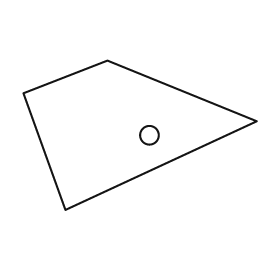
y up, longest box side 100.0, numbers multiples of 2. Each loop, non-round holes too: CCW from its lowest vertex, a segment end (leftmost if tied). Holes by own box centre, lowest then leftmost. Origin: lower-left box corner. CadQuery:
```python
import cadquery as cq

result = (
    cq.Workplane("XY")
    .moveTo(18.0, 0.0)
    .lineTo(100.0, 38.0)
    .lineTo(36.0, 64.0)
    .lineTo(0.0, 50.0)
    .close()
    .moveTo(54.0, 32.0)
    .circle(4.0)
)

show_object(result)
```